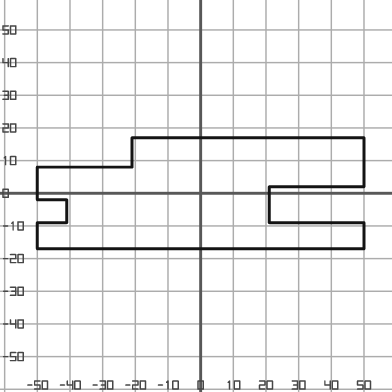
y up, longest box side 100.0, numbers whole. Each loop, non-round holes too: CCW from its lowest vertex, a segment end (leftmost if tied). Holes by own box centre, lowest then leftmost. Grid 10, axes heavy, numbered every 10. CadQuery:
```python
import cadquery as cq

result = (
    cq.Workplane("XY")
    .moveTo(-50.0, -17.0)
    .lineTo(50.0, -17.0)
    .lineTo(50.0, -9.0)
    .lineTo(21.0, -9.0)
    .lineTo(21.0, 2.0)
    .lineTo(50.0, 2.0)
    .lineTo(50.0, 17.0)
    .lineTo(-21.0, 17.0)
    .lineTo(-21.0, 8.0)
    .lineTo(-50.0, 8.0)
    .lineTo(-50.0, -2.0)
    .lineTo(-41.0, -2.0)
    .lineTo(-41.0, -9.0)
    .lineTo(-50.0, -9.0)
    .close()
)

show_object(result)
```